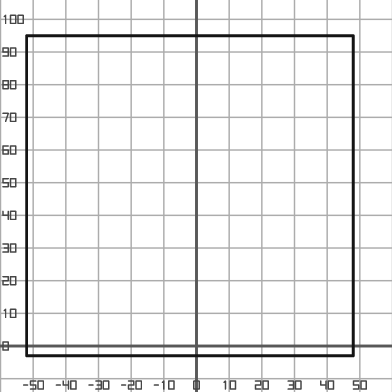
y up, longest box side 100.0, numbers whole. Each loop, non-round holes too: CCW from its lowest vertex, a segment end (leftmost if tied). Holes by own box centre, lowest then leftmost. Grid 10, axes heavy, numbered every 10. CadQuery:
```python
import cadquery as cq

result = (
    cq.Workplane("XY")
    .moveTo(-52.0, -3.0)
    .lineTo(48.0, -3.0)
    .lineTo(48.0, 95.0)
    .lineTo(-52.0, 95.0)
    .close()
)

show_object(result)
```